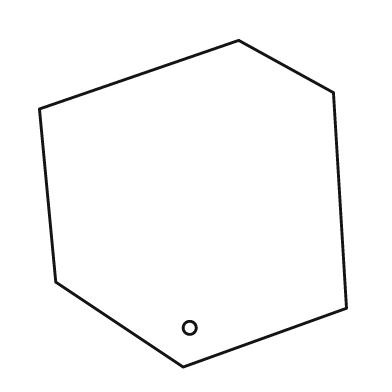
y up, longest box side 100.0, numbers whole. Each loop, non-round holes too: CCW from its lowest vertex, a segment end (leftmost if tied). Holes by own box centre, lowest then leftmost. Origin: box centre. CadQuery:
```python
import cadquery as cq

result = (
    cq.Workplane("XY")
    .moveTo(-3.0, -50.0)
    .lineTo(47.0, -32.0)
    .lineTo(43.0, 34.0)
    .lineTo(14.0, 50.0)
    .lineTo(-47.0, 29.0)
    .lineTo(-42.0, -24.0)
    .close()
    .moveTo(-1.0, -38.0)
    .circle(2.0)
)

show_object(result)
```